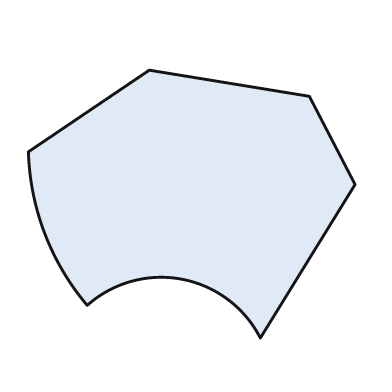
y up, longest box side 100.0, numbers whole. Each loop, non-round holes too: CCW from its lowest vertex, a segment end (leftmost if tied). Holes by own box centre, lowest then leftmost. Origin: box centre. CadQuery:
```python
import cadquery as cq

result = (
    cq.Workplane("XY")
    .moveTo(21.0, -41.0)
    .lineTo(50.0, 6.0)
    .lineTo(36.0, 33.0)
    .lineTo(-13.0, 41.0)
    .lineTo(-50.0, 16.0)
    .threePointArc((-45.0, -9.0), (-32.0, -31.0))
    .threePointArc((-3.0, -23.0), (21.0, -41.0))
    .close()
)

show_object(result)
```